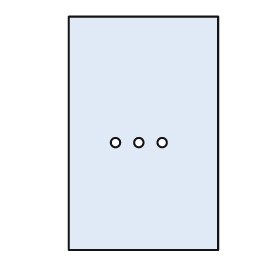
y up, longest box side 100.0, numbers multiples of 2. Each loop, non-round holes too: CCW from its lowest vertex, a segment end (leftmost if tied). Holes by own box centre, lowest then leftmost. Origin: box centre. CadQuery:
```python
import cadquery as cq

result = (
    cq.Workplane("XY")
    .moveTo(-32.0, -50.0)
    .lineTo(32.0, -50.0)
    .lineTo(32.0, 50.0)
    .lineTo(-32.0, 50.0)
    .close()
    .moveTo(-12.0, -4.0)
    .circle(2.0)
    .moveTo(-2.0, -4.0)
    .circle(2.0)
    .moveTo(8.0, -4.0)
    .circle(2.0)
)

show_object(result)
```